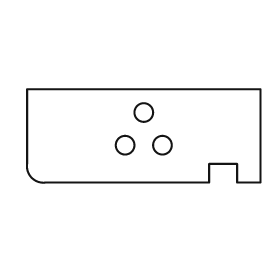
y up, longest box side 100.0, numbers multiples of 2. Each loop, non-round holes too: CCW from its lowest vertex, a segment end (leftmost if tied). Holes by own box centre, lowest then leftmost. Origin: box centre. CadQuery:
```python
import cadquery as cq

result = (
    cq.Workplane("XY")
    .moveTo(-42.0, -20.0)
    .lineTo(28.0, -20.0)
    .lineTo(28.0, -12.0)
    .lineTo(40.0, -12.0)
    .lineTo(40.0, -20.0)
    .lineTo(50.0, -20.0)
    .lineTo(50.0, 20.0)
    .lineTo(-50.0, 20.0)
    .lineTo(-50.0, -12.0)
    .threePointArc((-48.0, -18.0), (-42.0, -20.0))
    .close()
    .moveTo(-8.0, -4.0)
    .circle(4.0)
    .moveTo(8.0, -4.0)
    .circle(4.0)
    .moveTo(0.0, 10.0)
    .circle(4.0)
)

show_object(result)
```